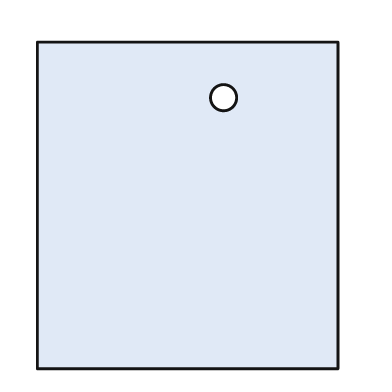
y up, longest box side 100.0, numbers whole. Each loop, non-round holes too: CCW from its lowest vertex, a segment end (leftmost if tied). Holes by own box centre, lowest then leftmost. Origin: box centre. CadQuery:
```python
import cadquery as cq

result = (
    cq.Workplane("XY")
    .moveTo(-46.0, -50.0)
    .lineTo(46.0, -50.0)
    .lineTo(46.0, 50.0)
    .lineTo(-46.0, 50.0)
    .close()
    .moveTo(11.0, 33.0)
    .circle(4.0)
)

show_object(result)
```